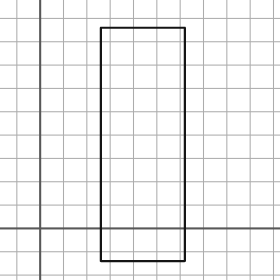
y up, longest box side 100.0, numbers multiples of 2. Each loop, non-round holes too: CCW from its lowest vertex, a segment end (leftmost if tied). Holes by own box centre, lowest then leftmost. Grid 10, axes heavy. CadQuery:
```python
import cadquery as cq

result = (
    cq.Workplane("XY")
    .moveTo(26.0, -14.0)
    .lineTo(62.0, -14.0)
    .lineTo(62.0, 86.0)
    .lineTo(26.0, 86.0)
    .close()
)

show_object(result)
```